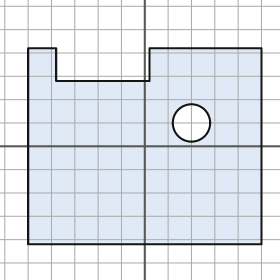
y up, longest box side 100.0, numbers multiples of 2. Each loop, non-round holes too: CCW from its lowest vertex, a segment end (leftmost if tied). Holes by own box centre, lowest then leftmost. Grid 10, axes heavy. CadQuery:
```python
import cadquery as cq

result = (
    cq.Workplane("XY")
    .moveTo(-50.0, -42.0)
    .lineTo(50.0, -42.0)
    .lineTo(50.0, 42.0)
    .lineTo(2.0, 42.0)
    .lineTo(2.0, 28.0)
    .lineTo(-38.0, 28.0)
    .lineTo(-38.0, 42.0)
    .lineTo(-50.0, 42.0)
    .close()
    .moveTo(20.0, 10.0)
    .circle(8.0)
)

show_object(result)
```